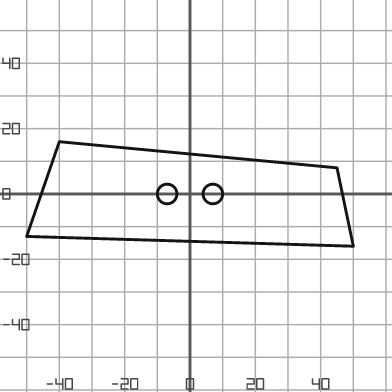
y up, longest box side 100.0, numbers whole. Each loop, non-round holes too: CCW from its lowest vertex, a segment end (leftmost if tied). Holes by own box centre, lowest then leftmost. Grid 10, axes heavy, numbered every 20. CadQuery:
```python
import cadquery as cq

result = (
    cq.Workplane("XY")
    .moveTo(50.0, -16.0)
    .lineTo(45.0, 8.0)
    .lineTo(-40.0, 16.0)
    .lineTo(-50.0, -13.0)
    .close()
    .moveTo(-7.0, 0.0)
    .circle(3.0)
    .moveTo(7.0, 0.0)
    .circle(3.0)
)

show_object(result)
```